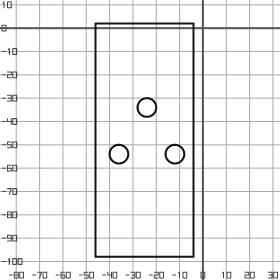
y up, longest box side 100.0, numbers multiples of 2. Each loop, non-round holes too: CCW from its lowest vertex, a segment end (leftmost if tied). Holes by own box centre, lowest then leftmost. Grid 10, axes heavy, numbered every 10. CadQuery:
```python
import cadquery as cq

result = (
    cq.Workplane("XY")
    .moveTo(-46.0, -98.0)
    .lineTo(-4.0, -98.0)
    .lineTo(-4.0, 2.0)
    .lineTo(-46.0, 2.0)
    .close()
    .moveTo(-36.0, -54.0)
    .circle(4.0)
    .moveTo(-12.0, -54.0)
    .circle(4.0)
    .moveTo(-24.0, -34.0)
    .circle(4.0)
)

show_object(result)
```